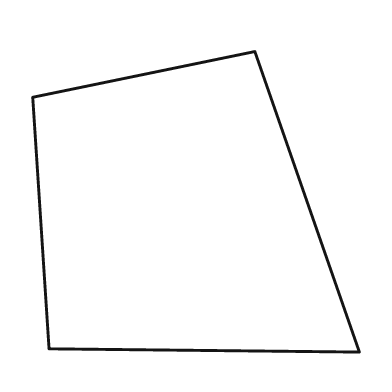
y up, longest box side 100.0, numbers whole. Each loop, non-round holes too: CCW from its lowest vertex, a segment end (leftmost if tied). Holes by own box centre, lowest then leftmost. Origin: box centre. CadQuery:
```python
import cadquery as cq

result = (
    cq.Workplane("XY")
    .moveTo(50.0, -46.0)
    .lineTo(18.0, 46.0)
    .lineTo(-50.0, 32.0)
    .lineTo(-45.0, -45.0)
    .close()
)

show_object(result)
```